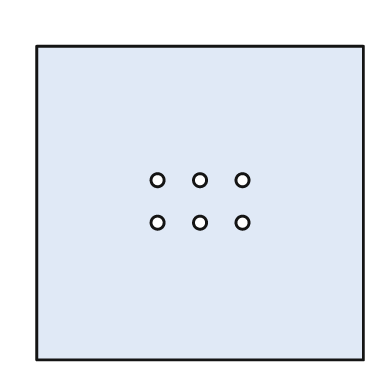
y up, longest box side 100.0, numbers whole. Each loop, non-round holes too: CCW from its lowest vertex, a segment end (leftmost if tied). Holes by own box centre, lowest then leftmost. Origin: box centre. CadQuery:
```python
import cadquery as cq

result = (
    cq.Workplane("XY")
    .moveTo(-50.0, -48.0)
    .lineTo(50.0, -48.0)
    .lineTo(50.0, 48.0)
    .lineTo(-50.0, 48.0)
    .close()
    .moveTo(-13.0, -6.0)
    .circle(2.0)
    .moveTo(0.0, -6.0)
    .circle(2.0)
    .moveTo(13.0, -6.0)
    .circle(2.0)
    .moveTo(-13.0, 7.0)
    .circle(2.0)
    .moveTo(0.0, 7.0)
    .circle(2.0)
    .moveTo(13.0, 7.0)
    .circle(2.0)
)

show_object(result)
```